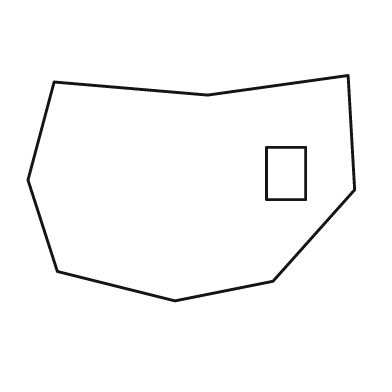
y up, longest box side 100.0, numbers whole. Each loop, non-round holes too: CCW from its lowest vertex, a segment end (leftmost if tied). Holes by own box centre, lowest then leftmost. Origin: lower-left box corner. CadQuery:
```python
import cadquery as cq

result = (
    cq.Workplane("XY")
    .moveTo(45.0, 0.0)
    .lineTo(75.0, 6.0)
    .lineTo(100.0, 34.0)
    .lineTo(98.0, 69.0)
    .lineTo(55.0, 63.0)
    .lineTo(8.0, 67.0)
    .lineTo(0.0, 37.0)
    .lineTo(9.0, 9.0)
    .close()
    .moveTo(73.0, 31.0)
    .lineTo(85.0, 31.0)
    .lineTo(85.0, 47.0)
    .lineTo(73.0, 47.0)
    .close()
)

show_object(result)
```